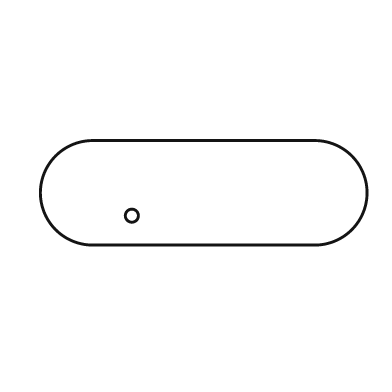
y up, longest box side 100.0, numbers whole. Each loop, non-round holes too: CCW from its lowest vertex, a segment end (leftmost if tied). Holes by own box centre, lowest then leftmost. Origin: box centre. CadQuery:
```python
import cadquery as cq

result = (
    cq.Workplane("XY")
    .moveTo(-34.0, -16.0)
    .lineTo(34.0, -16.0)
    .threePointArc((50.0, 0.0), (34.0, 16.0))
    .lineTo(-34.0, 16.0)
    .threePointArc((-50.0, 0.0), (-34.0, -16.0))
    .close()
    .moveTo(-22.0, -7.0)
    .circle(2.0)
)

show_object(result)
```